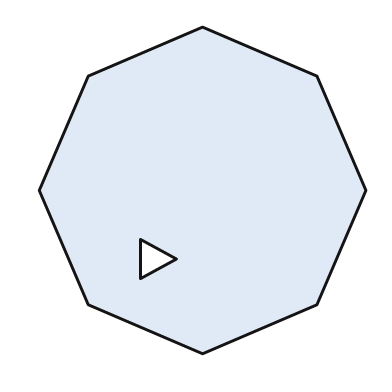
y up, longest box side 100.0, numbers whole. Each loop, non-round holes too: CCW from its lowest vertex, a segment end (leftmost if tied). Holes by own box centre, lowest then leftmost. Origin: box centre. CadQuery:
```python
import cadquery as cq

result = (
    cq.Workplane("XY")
    .moveTo(0.0, -50.0)
    .lineTo(35.0, -35.0)
    .lineTo(50.0, 0.0)
    .lineTo(35.0, 35.0)
    .lineTo(0.0, 50.0)
    .lineTo(-35.0, 35.0)
    .lineTo(-50.0, 0.0)
    .lineTo(-35.0, -35.0)
    .close()
    .moveTo(-19.0, -27.0)
    .lineTo(-8.0, -21.0)
    .lineTo(-19.0, -15.0)
    .close()
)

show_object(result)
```